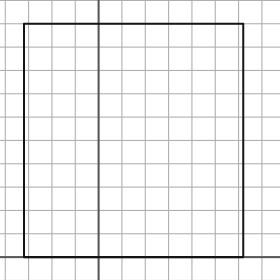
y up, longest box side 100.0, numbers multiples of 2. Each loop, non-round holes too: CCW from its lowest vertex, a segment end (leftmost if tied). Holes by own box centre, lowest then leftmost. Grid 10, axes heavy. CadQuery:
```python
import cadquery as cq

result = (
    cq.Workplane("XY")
    .moveTo(-32.0, 0.0)
    .lineTo(62.0, 0.0)
    .lineTo(62.0, 100.0)
    .lineTo(-32.0, 100.0)
    .close()
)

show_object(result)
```